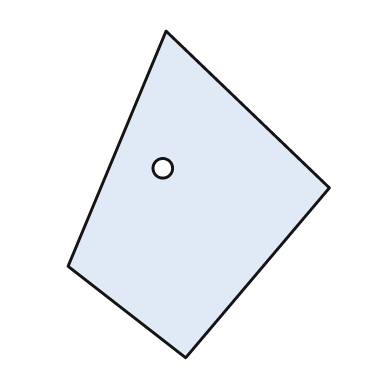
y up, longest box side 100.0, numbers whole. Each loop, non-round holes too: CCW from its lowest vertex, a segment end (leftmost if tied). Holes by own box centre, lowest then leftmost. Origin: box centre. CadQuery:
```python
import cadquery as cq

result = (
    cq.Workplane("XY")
    .moveTo(-4.0, -50.0)
    .lineTo(40.0, 2.0)
    .lineTo(-10.0, 50.0)
    .lineTo(-40.0, -22.0)
    .close()
    .moveTo(-11.0, 8.0)
    .circle(3.0)
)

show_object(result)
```